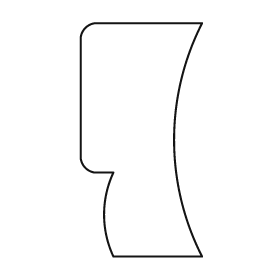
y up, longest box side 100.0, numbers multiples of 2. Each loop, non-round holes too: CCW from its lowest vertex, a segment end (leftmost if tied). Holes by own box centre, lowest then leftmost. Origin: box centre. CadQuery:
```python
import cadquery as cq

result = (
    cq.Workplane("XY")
    .moveTo(-12.0, -50.0)
    .lineTo(26.0, -50.0)
    .threePointArc((14.0, 0.0), (26.0, 50.0))
    .lineTo(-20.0, 50.0)
    .threePointArc((-24.0, 48.0), (-26.0, 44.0))
    .lineTo(-26.0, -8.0)
    .threePointArc((-24.0, -12.0), (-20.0, -14.0))
    .lineTo(-12.0, -14.0)
    .threePointArc((-16.0, -32.0), (-12.0, -50.0))
    .close()
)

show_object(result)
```